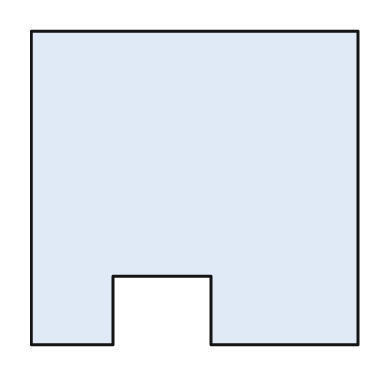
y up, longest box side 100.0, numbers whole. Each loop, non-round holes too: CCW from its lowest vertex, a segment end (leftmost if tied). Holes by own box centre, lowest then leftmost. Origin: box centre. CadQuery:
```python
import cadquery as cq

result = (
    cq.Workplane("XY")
    .moveTo(-50.0, -48.0)
    .lineTo(-25.0, -48.0)
    .lineTo(-25.0, -27.0)
    .lineTo(5.0, -27.0)
    .lineTo(5.0, -48.0)
    .lineTo(50.0, -48.0)
    .lineTo(50.0, 48.0)
    .lineTo(-50.0, 48.0)
    .close()
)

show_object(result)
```